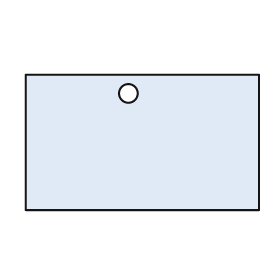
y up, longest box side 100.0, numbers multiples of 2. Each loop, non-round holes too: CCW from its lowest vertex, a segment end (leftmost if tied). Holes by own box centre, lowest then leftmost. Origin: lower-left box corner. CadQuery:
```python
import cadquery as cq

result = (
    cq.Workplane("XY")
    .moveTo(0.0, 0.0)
    .lineTo(100.0, 0.0)
    .lineTo(100.0, 58.0)
    .lineTo(0.0, 58.0)
    .close()
    .moveTo(44.0, 50.0)
    .circle(4.0)
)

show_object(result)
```